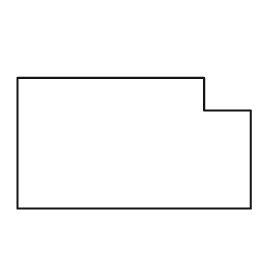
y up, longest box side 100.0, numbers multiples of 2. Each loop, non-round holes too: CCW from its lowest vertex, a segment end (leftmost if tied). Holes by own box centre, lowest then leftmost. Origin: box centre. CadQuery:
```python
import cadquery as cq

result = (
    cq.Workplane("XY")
    .moveTo(-50.0, -28.0)
    .lineTo(50.0, -28.0)
    .lineTo(50.0, 14.0)
    .lineTo(30.0, 14.0)
    .lineTo(30.0, 28.0)
    .lineTo(-50.0, 28.0)
    .close()
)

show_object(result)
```